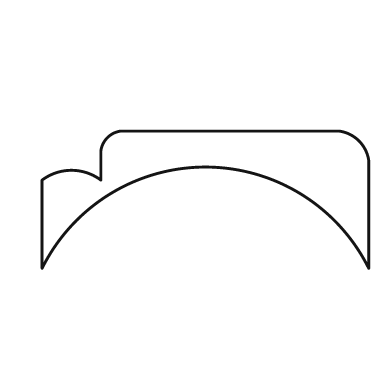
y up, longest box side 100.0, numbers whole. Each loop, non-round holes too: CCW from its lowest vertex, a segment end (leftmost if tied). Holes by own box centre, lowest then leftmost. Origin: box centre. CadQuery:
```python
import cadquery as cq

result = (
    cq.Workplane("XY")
    .moveTo(-50.0, -21.0)
    .threePointArc((0.0, 10.0), (50.0, -21.0))
    .lineTo(50.0, 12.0)
    .threePointArc((47.0, 18.0), (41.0, 21.0))
    .lineTo(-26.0, 21.0)
    .threePointArc((-30.0, 19.0), (-32.0, 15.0))
    .lineTo(-32.0, 6.0)
    .threePointArc((-41.0, 9.0), (-50.0, 6.0))
    .close()
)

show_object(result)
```